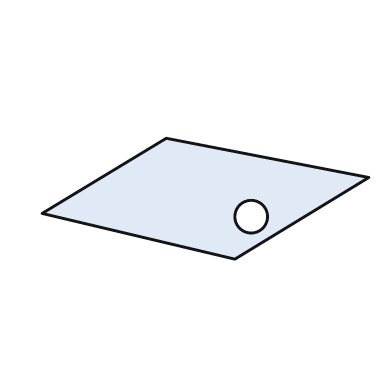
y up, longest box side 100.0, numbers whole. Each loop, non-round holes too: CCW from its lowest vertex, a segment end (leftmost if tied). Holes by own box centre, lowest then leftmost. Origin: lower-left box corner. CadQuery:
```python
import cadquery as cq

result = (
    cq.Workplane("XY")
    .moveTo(59.0, 0.0)
    .lineTo(100.0, 25.0)
    .lineTo(38.0, 37.0)
    .lineTo(0.0, 14.0)
    .close()
    .moveTo(64.0, 13.0)
    .circle(5.0)
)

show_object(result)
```